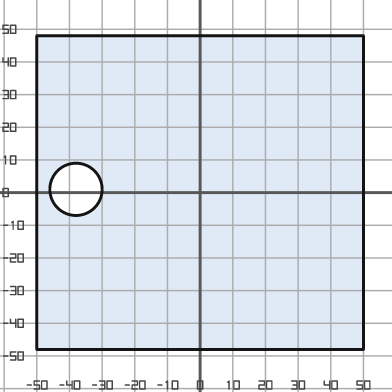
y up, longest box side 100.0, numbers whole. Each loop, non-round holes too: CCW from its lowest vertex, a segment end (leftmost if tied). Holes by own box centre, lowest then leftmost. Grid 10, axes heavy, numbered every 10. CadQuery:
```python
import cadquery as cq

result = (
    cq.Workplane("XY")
    .moveTo(-50.0, -48.0)
    .lineTo(50.0, -48.0)
    .lineTo(50.0, 48.0)
    .lineTo(-50.0, 48.0)
    .close()
    .moveTo(-38.0, 1.0)
    .circle(8.0)
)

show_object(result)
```